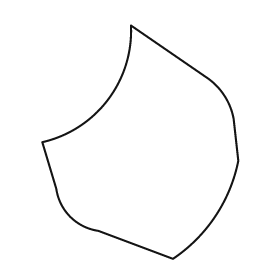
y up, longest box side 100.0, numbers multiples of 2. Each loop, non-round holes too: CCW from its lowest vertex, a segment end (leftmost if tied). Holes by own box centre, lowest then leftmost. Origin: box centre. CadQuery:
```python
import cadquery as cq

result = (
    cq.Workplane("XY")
    .moveTo(14.0, -50.0)
    .threePointArc((32.0, -32.0), (42.0, -8.0))
    .lineTo(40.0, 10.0)
    .threePointArc((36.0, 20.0), (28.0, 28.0))
    .lineTo(-4.0, 50.0)
    .threePointArc((-14.0, 18.0), (-42.0, 0.0))
    .lineTo(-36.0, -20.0)
    .threePointArc((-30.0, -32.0), (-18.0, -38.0))
    .close()
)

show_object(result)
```